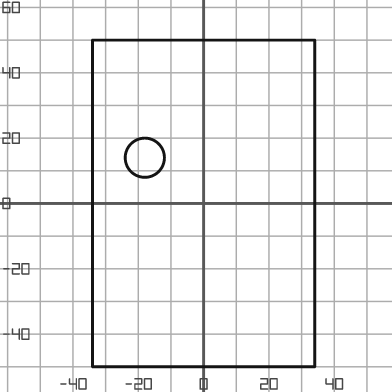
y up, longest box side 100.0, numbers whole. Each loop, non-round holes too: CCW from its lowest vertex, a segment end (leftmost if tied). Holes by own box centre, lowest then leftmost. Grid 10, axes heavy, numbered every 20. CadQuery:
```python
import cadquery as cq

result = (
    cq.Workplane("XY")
    .moveTo(-34.0, -50.0)
    .lineTo(34.0, -50.0)
    .lineTo(34.0, 50.0)
    .lineTo(-34.0, 50.0)
    .close()
    .moveTo(-18.0, 14.0)
    .circle(6.0)
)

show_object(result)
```